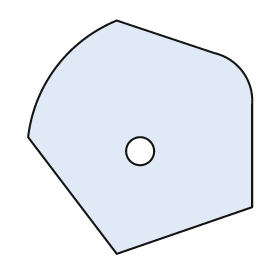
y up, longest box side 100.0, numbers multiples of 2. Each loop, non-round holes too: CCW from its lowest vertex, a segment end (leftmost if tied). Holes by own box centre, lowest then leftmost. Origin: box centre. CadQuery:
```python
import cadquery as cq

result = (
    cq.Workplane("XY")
    .moveTo(-10.0, -50.0)
    .lineTo(48.0, -30.0)
    .lineTo(48.0, 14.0)
    .threePointArc((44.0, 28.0), (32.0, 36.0))
    .lineTo(-10.0, 50.0)
    .threePointArc((-36.0, 30.0), (-48.0, 0.0))
    .close()
    .moveTo(0.0, -6.0)
    .circle(6.0)
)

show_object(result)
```